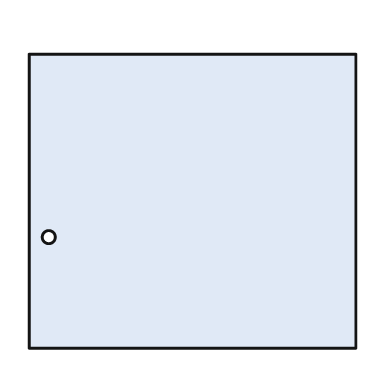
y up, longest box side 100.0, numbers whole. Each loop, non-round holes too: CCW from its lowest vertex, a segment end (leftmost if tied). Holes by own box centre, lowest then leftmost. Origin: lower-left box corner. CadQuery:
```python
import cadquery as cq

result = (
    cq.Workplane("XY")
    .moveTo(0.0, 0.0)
    .lineTo(100.0, 0.0)
    .lineTo(100.0, 90.0)
    .lineTo(0.0, 90.0)
    .close()
    .moveTo(6.0, 34.0)
    .circle(2.0)
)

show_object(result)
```